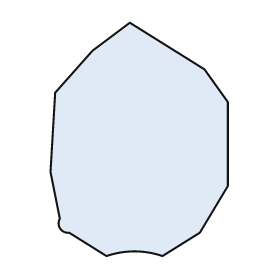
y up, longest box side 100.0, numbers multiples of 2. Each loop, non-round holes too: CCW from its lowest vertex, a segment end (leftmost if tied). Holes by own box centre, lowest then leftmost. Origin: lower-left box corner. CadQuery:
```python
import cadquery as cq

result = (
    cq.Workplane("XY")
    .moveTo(24.0, 0.0)
    .threePointArc((36.0, 2.0), (48.0, 0.0))
    .lineTo(64.0, 10.0)
    .lineTo(76.0, 30.0)
    .lineTo(76.0, 66.0)
    .lineTo(66.0, 80.0)
    .lineTo(34.0, 100.0)
    .lineTo(18.0, 88.0)
    .lineTo(2.0, 70.0)
    .lineTo(0.0, 36.0)
    .lineTo(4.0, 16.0)
    .threePointArc((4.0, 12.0), (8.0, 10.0))
    .close()
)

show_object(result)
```